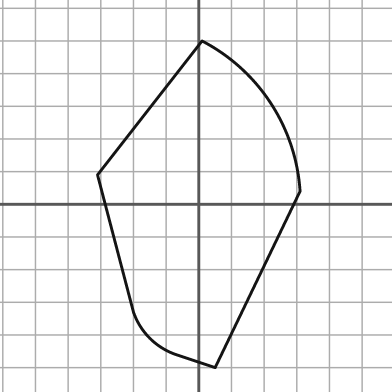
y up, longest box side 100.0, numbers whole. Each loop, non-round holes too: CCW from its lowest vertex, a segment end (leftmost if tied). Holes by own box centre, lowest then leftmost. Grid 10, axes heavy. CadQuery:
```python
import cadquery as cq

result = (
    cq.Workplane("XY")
    .moveTo(5.0, -50.0)
    .lineTo(31.0, 4.0)
    .threePointArc((22.0, 31.0), (1.0, 50.0))
    .lineTo(-31.0, 9.0)
    .lineTo(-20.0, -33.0)
    .threePointArc((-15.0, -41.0), (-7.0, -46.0))
    .close()
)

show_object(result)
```